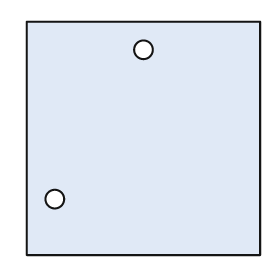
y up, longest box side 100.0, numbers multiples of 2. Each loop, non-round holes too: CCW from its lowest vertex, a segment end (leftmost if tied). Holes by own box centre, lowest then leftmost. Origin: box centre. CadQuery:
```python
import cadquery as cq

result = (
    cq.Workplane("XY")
    .moveTo(-50.0, -50.0)
    .lineTo(50.0, -50.0)
    .lineTo(50.0, 50.0)
    .lineTo(-50.0, 50.0)
    .close()
    .moveTo(-38.0, -26.0)
    .circle(4.0)
    .moveTo(0.0, 38.0)
    .circle(4.0)
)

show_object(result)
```